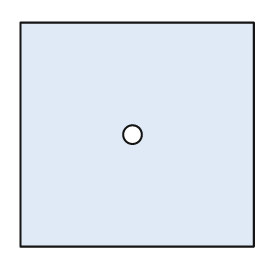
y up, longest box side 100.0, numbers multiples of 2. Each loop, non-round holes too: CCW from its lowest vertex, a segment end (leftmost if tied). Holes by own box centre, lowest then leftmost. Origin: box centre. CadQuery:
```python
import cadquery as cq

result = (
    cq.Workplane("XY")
    .moveTo(-50.0, -48.0)
    .lineTo(50.0, -48.0)
    .lineTo(50.0, 48.0)
    .lineTo(-50.0, 48.0)
    .close()
    .moveTo(-2.0, 0.0)
    .circle(4.0)
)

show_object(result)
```